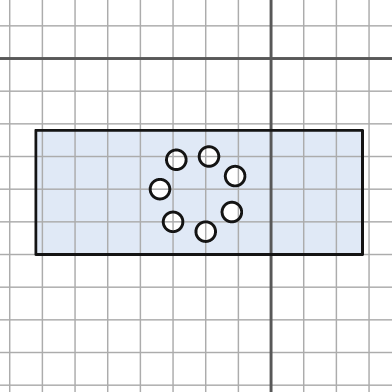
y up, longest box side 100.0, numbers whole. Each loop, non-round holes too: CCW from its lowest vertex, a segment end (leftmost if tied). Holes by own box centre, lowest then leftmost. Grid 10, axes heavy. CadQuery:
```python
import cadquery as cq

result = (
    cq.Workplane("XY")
    .moveTo(-72.0, -60.0)
    .lineTo(28.0, -60.0)
    .lineTo(28.0, -22.0)
    .lineTo(-72.0, -22.0)
    .close()
    .moveTo(-20.0, -53.0)
    .circle(3.0)
    .moveTo(-30.0, -50.0)
    .circle(3.0)
    .moveTo(-12.0, -47.0)
    .circle(3.0)
    .moveTo(-34.0, -40.0)
    .circle(3.0)
    .moveTo(-11.0, -36.0)
    .circle(3.0)
    .moveTo(-29.0, -31.0)
    .circle(3.0)
    .moveTo(-19.0, -30.0)
    .circle(3.0)
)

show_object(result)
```